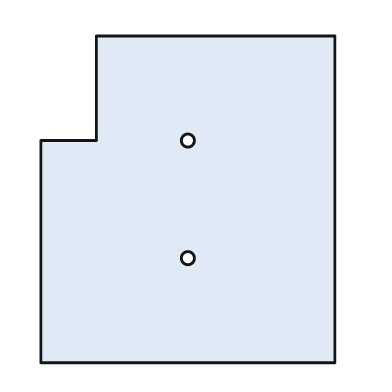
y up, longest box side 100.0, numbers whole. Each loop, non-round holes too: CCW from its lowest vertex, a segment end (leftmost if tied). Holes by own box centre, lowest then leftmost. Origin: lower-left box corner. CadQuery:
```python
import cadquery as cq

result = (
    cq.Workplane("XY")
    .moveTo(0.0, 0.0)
    .lineTo(90.0, 0.0)
    .lineTo(90.0, 100.0)
    .lineTo(17.0, 100.0)
    .lineTo(17.0, 68.0)
    .lineTo(0.0, 68.0)
    .close()
    .moveTo(45.0, 32.0)
    .circle(2.0)
    .moveTo(45.0, 68.0)
    .circle(2.0)
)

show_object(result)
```